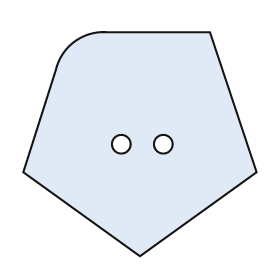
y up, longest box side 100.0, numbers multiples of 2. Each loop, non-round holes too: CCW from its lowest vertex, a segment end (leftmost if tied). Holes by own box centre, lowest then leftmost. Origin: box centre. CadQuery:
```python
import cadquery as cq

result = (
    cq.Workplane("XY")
    .moveTo(0.0, -48.0)
    .lineTo(50.0, -12.0)
    .lineTo(30.0, 48.0)
    .lineTo(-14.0, 48.0)
    .threePointArc((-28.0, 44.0), (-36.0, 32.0))
    .lineTo(-50.0, -12.0)
    .close()
    .moveTo(-8.0, 0.0)
    .circle(4.0)
    .moveTo(10.0, 0.0)
    .circle(4.0)
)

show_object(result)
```